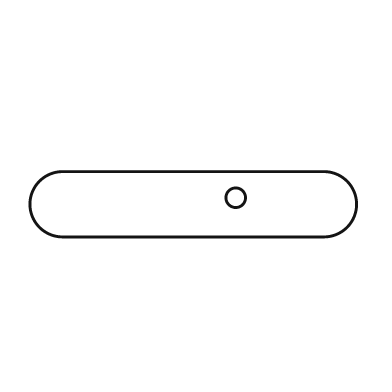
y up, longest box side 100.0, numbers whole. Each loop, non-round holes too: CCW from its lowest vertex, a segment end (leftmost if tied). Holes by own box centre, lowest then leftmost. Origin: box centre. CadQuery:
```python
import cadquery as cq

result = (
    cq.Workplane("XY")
    .moveTo(-40.0, -10.0)
    .lineTo(40.0, -10.0)
    .threePointArc((50.0, 0.0), (40.0, 10.0))
    .lineTo(-40.0, 10.0)
    .threePointArc((-50.0, 0.0), (-40.0, -10.0))
    .close()
    .moveTo(13.0, 2.0)
    .circle(3.0)
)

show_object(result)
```